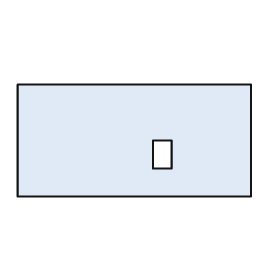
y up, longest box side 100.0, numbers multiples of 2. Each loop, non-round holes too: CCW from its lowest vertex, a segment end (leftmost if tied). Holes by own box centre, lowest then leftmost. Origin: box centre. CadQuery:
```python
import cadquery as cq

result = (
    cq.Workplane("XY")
    .moveTo(-50.0, -24.0)
    .lineTo(50.0, -24.0)
    .lineTo(50.0, 24.0)
    .lineTo(-50.0, 24.0)
    .close()
    .moveTo(8.0, -12.0)
    .lineTo(16.0, -12.0)
    .lineTo(16.0, 0.0)
    .lineTo(8.0, 0.0)
    .close()
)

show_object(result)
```